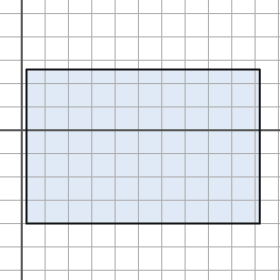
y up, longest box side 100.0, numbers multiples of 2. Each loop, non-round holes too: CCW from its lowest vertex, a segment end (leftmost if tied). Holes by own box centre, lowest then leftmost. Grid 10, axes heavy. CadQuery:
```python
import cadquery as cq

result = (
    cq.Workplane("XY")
    .moveTo(2.0, -40.0)
    .lineTo(102.0, -40.0)
    .lineTo(102.0, 26.0)
    .lineTo(2.0, 26.0)
    .close()
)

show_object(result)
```